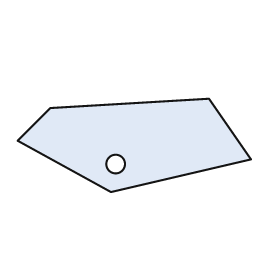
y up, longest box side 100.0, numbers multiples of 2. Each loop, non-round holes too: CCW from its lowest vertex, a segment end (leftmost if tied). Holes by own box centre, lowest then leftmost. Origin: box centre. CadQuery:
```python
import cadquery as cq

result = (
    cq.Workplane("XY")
    .moveTo(-10.0, -20.0)
    .lineTo(50.0, -6.0)
    .lineTo(32.0, 20.0)
    .lineTo(-36.0, 16.0)
    .lineTo(-50.0, 2.0)
    .close()
    .moveTo(-8.0, -8.0)
    .circle(4.0)
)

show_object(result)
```